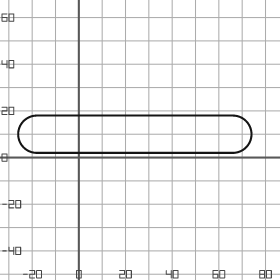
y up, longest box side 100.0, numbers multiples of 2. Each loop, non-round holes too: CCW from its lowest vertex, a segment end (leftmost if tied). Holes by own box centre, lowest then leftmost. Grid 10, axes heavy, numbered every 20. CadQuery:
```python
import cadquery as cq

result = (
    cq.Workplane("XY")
    .moveTo(-18.0, 2.0)
    .lineTo(66.0, 2.0)
    .threePointArc((74.0, 10.0), (66.0, 18.0))
    .lineTo(-18.0, 18.0)
    .threePointArc((-26.0, 10.0), (-18.0, 2.0))
    .close()
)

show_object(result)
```